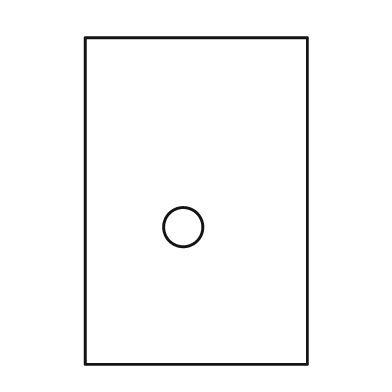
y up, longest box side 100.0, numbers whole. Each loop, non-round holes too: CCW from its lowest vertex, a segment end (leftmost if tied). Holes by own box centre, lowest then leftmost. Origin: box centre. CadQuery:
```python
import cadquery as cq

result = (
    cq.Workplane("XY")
    .moveTo(-34.0, -50.0)
    .lineTo(34.0, -50.0)
    .lineTo(34.0, 50.0)
    .lineTo(-34.0, 50.0)
    .close()
    .moveTo(-4.0, -8.0)
    .circle(6.0)
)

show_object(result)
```